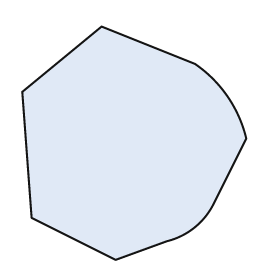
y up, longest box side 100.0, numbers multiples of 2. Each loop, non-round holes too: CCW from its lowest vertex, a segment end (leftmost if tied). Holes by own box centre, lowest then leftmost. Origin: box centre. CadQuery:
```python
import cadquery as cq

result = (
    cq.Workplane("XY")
    .moveTo(-8.0, -50.0)
    .lineTo(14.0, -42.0)
    .threePointArc((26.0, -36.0), (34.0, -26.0))
    .lineTo(48.0, 2.0)
    .threePointArc((40.0, 20.0), (26.0, 34.0))
    .lineTo(-14.0, 50.0)
    .lineTo(-48.0, 22.0)
    .lineTo(-44.0, -32.0)
    .close()
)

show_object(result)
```